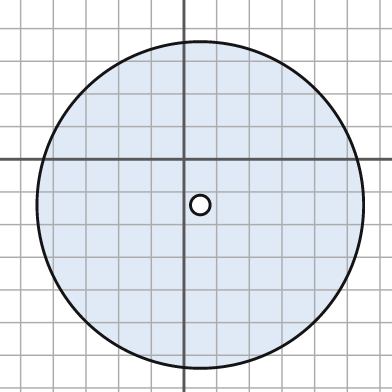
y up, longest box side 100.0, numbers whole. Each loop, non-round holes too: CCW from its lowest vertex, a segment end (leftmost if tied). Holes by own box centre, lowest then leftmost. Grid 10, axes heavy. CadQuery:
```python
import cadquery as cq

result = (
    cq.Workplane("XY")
    .moveTo(5.0, -14.0)
    .circle(50.0)
    .moveTo(5.0, -14.0)
    .circle(3.0)
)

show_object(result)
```